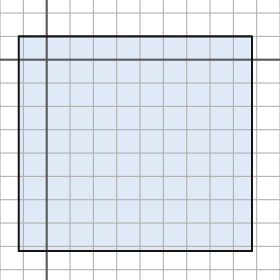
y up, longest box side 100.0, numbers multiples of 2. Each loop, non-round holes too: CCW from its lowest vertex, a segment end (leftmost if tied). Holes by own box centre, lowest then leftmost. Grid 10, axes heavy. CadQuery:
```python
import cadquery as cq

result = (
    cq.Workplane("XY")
    .moveTo(-12.0, -82.0)
    .lineTo(88.0, -82.0)
    .lineTo(88.0, 10.0)
    .lineTo(-12.0, 10.0)
    .close()
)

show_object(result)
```